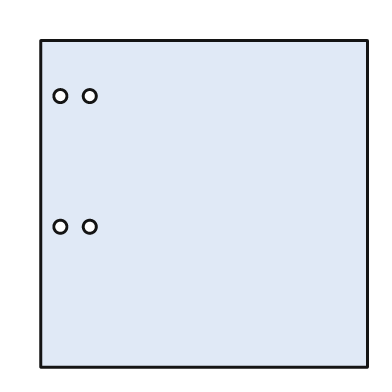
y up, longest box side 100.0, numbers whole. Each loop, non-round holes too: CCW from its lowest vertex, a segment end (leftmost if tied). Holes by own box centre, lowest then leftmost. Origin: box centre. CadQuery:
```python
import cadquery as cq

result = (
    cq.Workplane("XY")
    .moveTo(-50.0, -50.0)
    .lineTo(50.0, -50.0)
    .lineTo(50.0, 50.0)
    .lineTo(-50.0, 50.0)
    .close()
    .moveTo(-44.0, -7.0)
    .circle(2.0)
    .moveTo(-35.0, -7.0)
    .circle(2.0)
    .moveTo(-44.0, 33.0)
    .circle(2.0)
    .moveTo(-35.0, 33.0)
    .circle(2.0)
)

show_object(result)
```